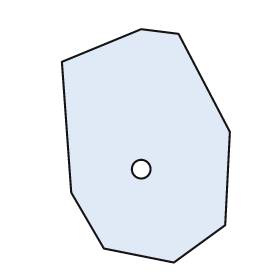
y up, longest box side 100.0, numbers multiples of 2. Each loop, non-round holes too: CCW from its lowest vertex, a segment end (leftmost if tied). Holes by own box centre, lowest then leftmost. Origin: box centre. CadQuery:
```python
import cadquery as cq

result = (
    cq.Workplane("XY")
    .moveTo(12.0, -50.0)
    .lineTo(34.0, -34.0)
    .lineTo(36.0, 6.0)
    .lineTo(14.0, 48.0)
    .lineTo(-2.0, 50.0)
    .lineTo(-36.0, 36.0)
    .lineTo(-32.0, -20.0)
    .lineTo(-18.0, -44.0)
    .close()
    .moveTo(-2.0, -10.0)
    .circle(4.0)
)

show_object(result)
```